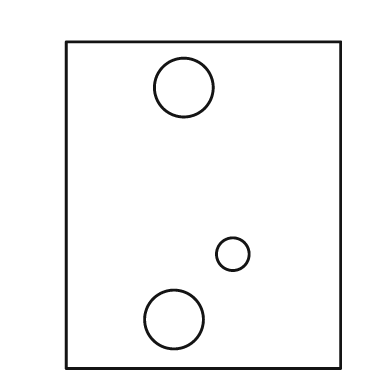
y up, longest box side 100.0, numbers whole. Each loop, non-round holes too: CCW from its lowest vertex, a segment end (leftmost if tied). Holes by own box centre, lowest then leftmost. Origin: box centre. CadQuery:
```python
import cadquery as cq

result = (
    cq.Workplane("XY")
    .moveTo(-42.0, -50.0)
    .lineTo(42.0, -50.0)
    .lineTo(42.0, 50.0)
    .lineTo(-42.0, 50.0)
    .close()
    .moveTo(-9.0, -35.0)
    .circle(9.0)
    .moveTo(9.0, -15.0)
    .circle(5.0)
    .moveTo(-6.0, 36.0)
    .circle(9.0)
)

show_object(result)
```